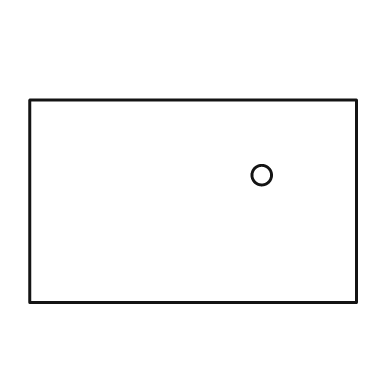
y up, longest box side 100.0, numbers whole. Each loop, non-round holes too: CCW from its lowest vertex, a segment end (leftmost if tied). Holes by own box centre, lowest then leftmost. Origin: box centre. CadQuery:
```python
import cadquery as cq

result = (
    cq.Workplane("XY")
    .moveTo(-50.0, -31.0)
    .lineTo(50.0, -31.0)
    .lineTo(50.0, 31.0)
    .lineTo(-50.0, 31.0)
    .close()
    .moveTo(21.0, 8.0)
    .circle(3.0)
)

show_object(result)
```